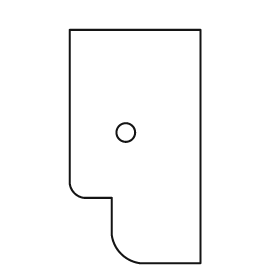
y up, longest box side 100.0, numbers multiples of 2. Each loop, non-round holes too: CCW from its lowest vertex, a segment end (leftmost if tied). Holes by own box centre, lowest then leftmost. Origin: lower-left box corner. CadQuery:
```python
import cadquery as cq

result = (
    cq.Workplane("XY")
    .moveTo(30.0, 0.0)
    .lineTo(56.0, 0.0)
    .lineTo(56.0, 100.0)
    .lineTo(0.0, 100.0)
    .lineTo(0.0, 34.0)
    .threePointArc((2.0, 30.0), (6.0, 28.0))
    .lineTo(18.0, 28.0)
    .lineTo(18.0, 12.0)
    .threePointArc((22.0, 4.0), (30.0, 0.0))
    .close()
    .moveTo(24.0, 56.0)
    .circle(4.0)
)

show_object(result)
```